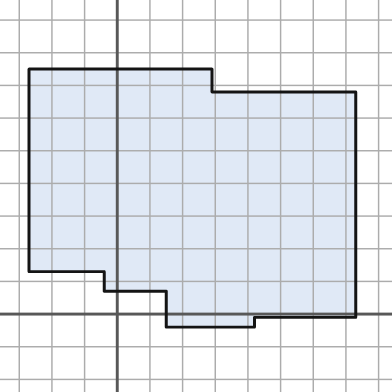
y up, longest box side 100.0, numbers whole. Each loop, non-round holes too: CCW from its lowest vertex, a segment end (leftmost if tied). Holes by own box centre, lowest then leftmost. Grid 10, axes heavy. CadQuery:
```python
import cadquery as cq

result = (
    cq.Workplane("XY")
    .moveTo(15.0, -4.0)
    .lineTo(42.0, -4.0)
    .lineTo(42.0, -1.0)
    .lineTo(73.0, -1.0)
    .lineTo(73.0, 68.0)
    .lineTo(29.0, 68.0)
    .lineTo(29.0, 75.0)
    .lineTo(-27.0, 75.0)
    .lineTo(-27.0, 13.0)
    .lineTo(-4.0, 13.0)
    .lineTo(-4.0, 7.0)
    .lineTo(15.0, 7.0)
    .close()
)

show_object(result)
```